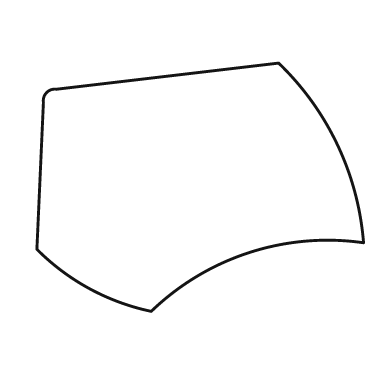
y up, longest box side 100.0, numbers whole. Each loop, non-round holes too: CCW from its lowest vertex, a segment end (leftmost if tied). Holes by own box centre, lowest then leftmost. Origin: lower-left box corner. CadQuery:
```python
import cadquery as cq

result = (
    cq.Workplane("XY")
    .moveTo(35.0, 0.0)
    .threePointArc((65.0, 18.0), (100.0, 21.0))
    .threePointArc((92.0, 51.0), (74.0, 76.0))
    .lineTo(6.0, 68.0)
    .threePointArc((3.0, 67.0), (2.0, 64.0))
    .lineTo(0.0, 19.0)
    .threePointArc((16.0, 7.0), (35.0, 0.0))
    .close()
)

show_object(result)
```